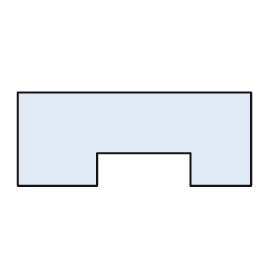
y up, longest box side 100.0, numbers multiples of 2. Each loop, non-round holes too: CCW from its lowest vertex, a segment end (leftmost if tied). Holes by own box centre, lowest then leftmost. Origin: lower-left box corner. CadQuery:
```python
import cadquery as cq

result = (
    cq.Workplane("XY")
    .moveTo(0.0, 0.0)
    .lineTo(34.0, 0.0)
    .lineTo(34.0, 14.0)
    .lineTo(74.0, 14.0)
    .lineTo(74.0, 0.0)
    .lineTo(100.0, 0.0)
    .lineTo(100.0, 40.0)
    .lineTo(0.0, 40.0)
    .close()
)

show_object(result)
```